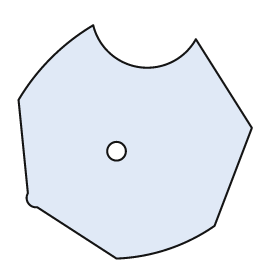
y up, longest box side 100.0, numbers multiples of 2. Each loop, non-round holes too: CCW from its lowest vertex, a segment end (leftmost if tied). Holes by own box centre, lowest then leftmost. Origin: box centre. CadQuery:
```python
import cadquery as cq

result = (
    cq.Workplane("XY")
    .moveTo(-8.0, -50.0)
    .threePointArc((14.0, -46.0), (34.0, -36.0))
    .lineTo(50.0, 6.0)
    .lineTo(26.0, 44.0)
    .threePointArc((2.0, 32.0), (-18.0, 50.0))
    .threePointArc((-36.0, 36.0), (-50.0, 18.0))
    .lineTo(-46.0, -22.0)
    .threePointArc((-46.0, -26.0), (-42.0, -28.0))
    .close()
    .moveTo(-8.0, -4.0)
    .circle(4.0)
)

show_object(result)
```